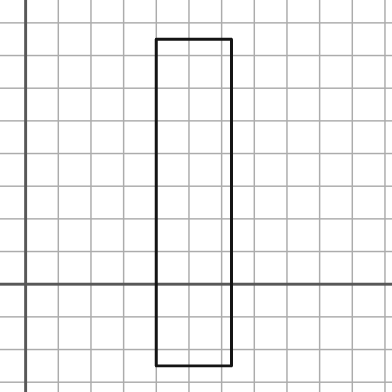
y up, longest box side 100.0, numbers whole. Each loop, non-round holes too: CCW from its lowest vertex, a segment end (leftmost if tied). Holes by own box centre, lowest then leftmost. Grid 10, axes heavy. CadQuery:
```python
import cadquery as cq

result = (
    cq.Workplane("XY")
    .moveTo(40.0, -25.0)
    .lineTo(63.0, -25.0)
    .lineTo(63.0, 75.0)
    .lineTo(40.0, 75.0)
    .close()
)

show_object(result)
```